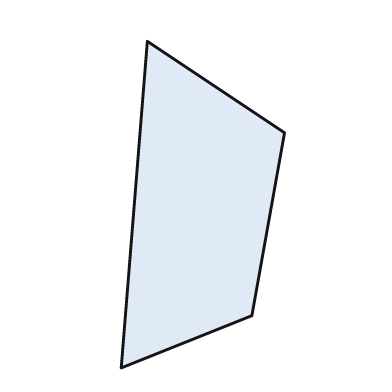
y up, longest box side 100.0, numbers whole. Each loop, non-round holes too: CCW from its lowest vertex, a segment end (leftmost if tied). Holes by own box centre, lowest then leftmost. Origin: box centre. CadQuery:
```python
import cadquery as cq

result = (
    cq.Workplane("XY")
    .moveTo(-25.0, -50.0)
    .lineTo(15.0, -34.0)
    .lineTo(25.0, 22.0)
    .lineTo(-17.0, 50.0)
    .close()
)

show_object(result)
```